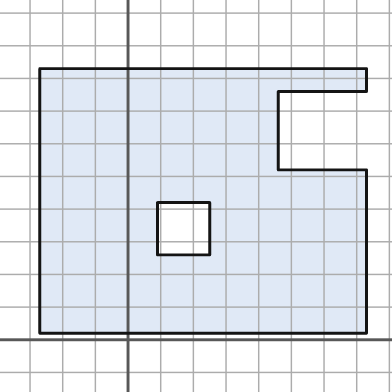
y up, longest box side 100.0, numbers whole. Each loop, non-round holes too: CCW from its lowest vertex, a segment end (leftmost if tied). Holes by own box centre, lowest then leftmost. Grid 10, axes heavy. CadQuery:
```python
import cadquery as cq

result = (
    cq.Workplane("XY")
    .moveTo(-27.0, 2.0)
    .lineTo(73.0, 2.0)
    .lineTo(73.0, 52.0)
    .lineTo(46.0, 52.0)
    .lineTo(46.0, 76.0)
    .lineTo(73.0, 76.0)
    .lineTo(73.0, 83.0)
    .lineTo(-27.0, 83.0)
    .close()
    .moveTo(9.0, 26.0)
    .lineTo(25.0, 26.0)
    .lineTo(25.0, 42.0)
    .lineTo(9.0, 42.0)
    .close()
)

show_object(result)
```